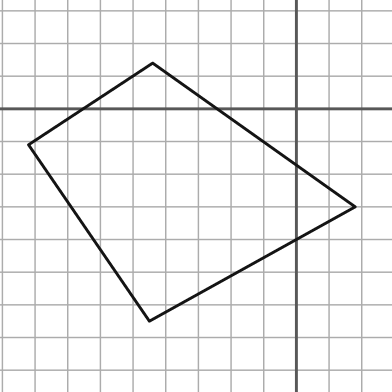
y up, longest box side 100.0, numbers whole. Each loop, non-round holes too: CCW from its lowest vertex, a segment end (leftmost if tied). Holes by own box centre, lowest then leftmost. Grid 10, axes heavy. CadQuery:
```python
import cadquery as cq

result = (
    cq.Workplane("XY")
    .moveTo(-45.0, -65.0)
    .lineTo(18.0, -30.0)
    .lineTo(-44.0, 14.0)
    .lineTo(-82.0, -11.0)
    .close()
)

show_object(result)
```